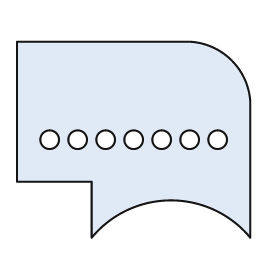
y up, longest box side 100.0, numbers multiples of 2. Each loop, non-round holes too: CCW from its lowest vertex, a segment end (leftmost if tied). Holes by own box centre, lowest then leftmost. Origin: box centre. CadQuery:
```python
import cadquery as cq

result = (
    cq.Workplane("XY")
    .moveTo(-18.0, -42.0)
    .threePointArc((16.0, -26.0), (50.0, -42.0))
    .lineTo(50.0, 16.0)
    .threePointArc((42.0, 34.0), (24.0, 42.0))
    .lineTo(-50.0, 42.0)
    .lineTo(-50.0, -18.0)
    .lineTo(-18.0, -18.0)
    .close()
    .moveTo(-36.0, 0.0)
    .circle(4.0)
    .moveTo(-24.0, 0.0)
    .circle(4.0)
    .moveTo(-12.0, 0.0)
    .circle(4.0)
    .moveTo(0.0, 0.0)
    .circle(4.0)
    .moveTo(12.0, 0.0)
    .circle(4.0)
    .moveTo(24.0, 0.0)
    .circle(4.0)
    .moveTo(36.0, 0.0)
    .circle(4.0)
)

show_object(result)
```